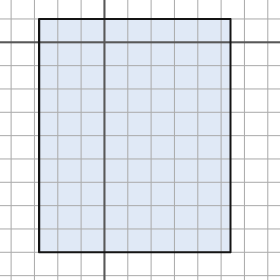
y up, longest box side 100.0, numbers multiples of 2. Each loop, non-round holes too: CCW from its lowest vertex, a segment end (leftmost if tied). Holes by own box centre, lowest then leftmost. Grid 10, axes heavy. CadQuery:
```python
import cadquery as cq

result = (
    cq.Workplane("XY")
    .moveTo(-28.0, -90.0)
    .lineTo(54.0, -90.0)
    .lineTo(54.0, 10.0)
    .lineTo(-28.0, 10.0)
    .close()
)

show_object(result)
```